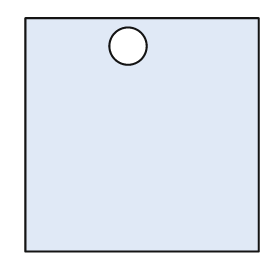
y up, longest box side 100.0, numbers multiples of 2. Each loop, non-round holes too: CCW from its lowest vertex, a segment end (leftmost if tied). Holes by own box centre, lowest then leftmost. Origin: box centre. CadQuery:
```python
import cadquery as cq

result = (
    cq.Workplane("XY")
    .moveTo(-50.0, -50.0)
    .lineTo(50.0, -50.0)
    .lineTo(50.0, 50.0)
    .lineTo(-50.0, 50.0)
    .close()
    .moveTo(-6.0, 38.0)
    .circle(8.0)
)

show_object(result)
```